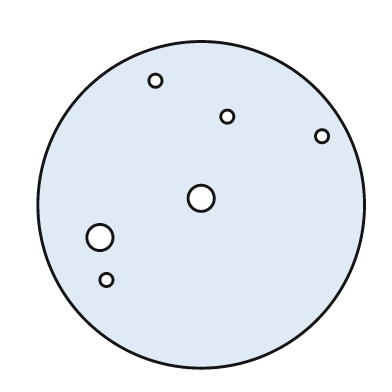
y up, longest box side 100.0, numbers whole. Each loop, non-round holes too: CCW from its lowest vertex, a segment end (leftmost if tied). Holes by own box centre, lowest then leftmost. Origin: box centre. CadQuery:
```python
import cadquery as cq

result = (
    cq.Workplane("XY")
    .moveTo(0.0, 0.0)
    .circle(50.0)
    .moveTo(-29.0, -23.0)
    .circle(2.0)
    .moveTo(-31.0, -10.0)
    .circle(4.0)
    .moveTo(0.0, 2.0)
    .circle(4.0)
    .moveTo(37.0, 21.0)
    .circle(2.0)
    .moveTo(8.0, 27.0)
    .circle(2.0)
    .moveTo(-14.0, 38.0)
    .circle(2.0)
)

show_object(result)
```